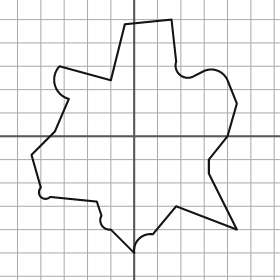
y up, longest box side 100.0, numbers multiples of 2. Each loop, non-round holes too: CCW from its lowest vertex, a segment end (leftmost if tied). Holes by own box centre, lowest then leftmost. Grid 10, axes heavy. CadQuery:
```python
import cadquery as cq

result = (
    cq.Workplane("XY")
    .moveTo(0.0, -50.0)
    .threePointArc((2.0, -44.0), (8.0, -42.0))
    .lineTo(18.0, -30.0)
    .lineTo(44.0, -40.0)
    .lineTo(32.0, -16.0)
    .lineTo(32.0, -10.0)
    .lineTo(40.0, 0.0)
    .lineTo(44.0, 14.0)
    .lineTo(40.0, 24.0)
    .threePointArc((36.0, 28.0), (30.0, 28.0))
    .lineTo(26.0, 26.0)
    .threePointArc((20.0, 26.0), (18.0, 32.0))
    .lineTo(16.0, 50.0)
    .lineTo(-4.0, 48.0)
    .lineTo(-10.0, 24.0)
    .lineTo(-32.0, 30.0)
    .threePointArc((-34.0, 22.0), (-28.0, 16.0))
    .lineTo(-34.0, 2.0)
    .lineTo(-44.0, -8.0)
    .lineTo(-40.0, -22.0)
    .threePointArc((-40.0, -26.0), (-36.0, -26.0))
    .lineTo(-16.0, -28.0)
    .lineTo(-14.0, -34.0)
    .threePointArc((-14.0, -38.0), (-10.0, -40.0))
    .close()
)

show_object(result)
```